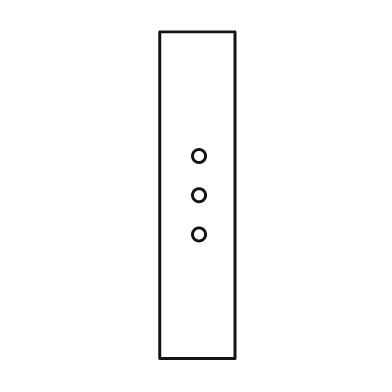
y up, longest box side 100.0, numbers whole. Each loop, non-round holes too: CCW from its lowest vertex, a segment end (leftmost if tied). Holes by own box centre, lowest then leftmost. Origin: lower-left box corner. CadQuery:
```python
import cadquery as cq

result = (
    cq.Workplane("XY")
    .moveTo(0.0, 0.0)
    .lineTo(23.0, 0.0)
    .lineTo(23.0, 100.0)
    .lineTo(0.0, 100.0)
    .close()
    .moveTo(12.0, 38.0)
    .circle(2.0)
    .moveTo(12.0, 50.0)
    .circle(2.0)
    .moveTo(12.0, 62.0)
    .circle(2.0)
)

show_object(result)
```